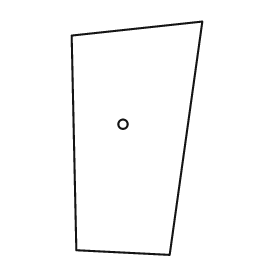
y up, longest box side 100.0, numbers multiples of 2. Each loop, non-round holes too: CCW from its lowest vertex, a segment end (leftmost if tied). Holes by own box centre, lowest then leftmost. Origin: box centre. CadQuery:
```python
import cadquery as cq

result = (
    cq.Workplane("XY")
    .moveTo(14.0, -50.0)
    .lineTo(28.0, 50.0)
    .lineTo(-28.0, 44.0)
    .lineTo(-26.0, -48.0)
    .close()
    .moveTo(-6.0, 6.0)
    .circle(2.0)
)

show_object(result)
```